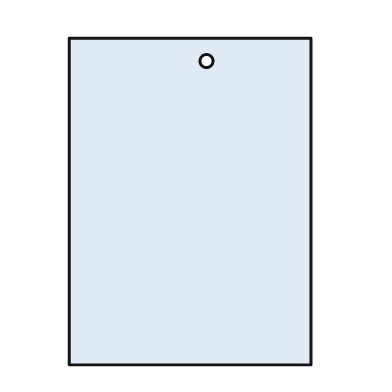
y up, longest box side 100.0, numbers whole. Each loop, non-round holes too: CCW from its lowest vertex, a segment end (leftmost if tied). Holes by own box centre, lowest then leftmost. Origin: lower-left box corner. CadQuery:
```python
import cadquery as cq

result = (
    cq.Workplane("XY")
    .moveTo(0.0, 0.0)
    .lineTo(74.0, 0.0)
    .lineTo(74.0, 100.0)
    .lineTo(0.0, 100.0)
    .close()
    .moveTo(42.0, 93.0)
    .circle(2.0)
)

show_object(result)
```